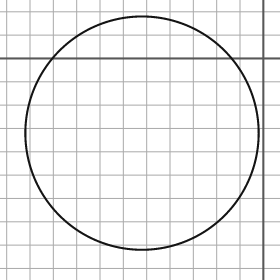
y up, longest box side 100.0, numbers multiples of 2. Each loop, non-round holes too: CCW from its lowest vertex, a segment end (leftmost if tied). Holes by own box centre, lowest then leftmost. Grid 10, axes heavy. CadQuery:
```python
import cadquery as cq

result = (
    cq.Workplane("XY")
    .moveTo(-52.0, -32.0)
    .circle(50.0)
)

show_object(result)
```